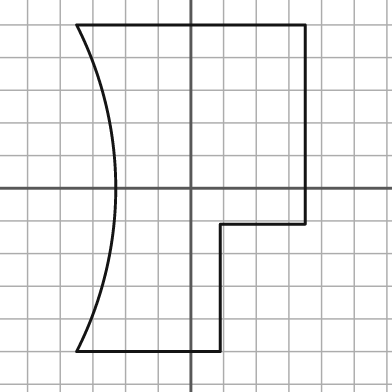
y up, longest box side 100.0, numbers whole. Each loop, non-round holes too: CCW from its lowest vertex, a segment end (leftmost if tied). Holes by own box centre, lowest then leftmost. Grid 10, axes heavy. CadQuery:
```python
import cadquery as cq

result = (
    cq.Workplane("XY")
    .moveTo(-35.0, -50.0)
    .lineTo(9.0, -50.0)
    .lineTo(9.0, -11.0)
    .lineTo(35.0, -11.0)
    .lineTo(35.0, 50.0)
    .lineTo(-35.0, 50.0)
    .threePointArc((-23.0, 0.0), (-35.0, -50.0))
    .close()
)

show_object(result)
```